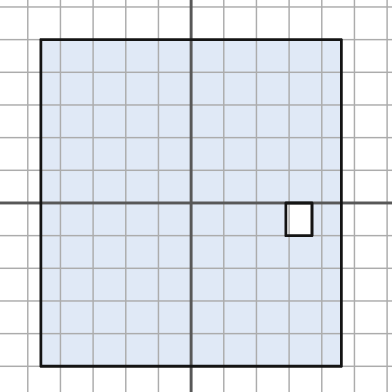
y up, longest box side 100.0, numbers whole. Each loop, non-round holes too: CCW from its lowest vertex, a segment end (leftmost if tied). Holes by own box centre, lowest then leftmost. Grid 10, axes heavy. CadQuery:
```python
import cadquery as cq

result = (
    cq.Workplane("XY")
    .moveTo(-46.0, -50.0)
    .lineTo(46.0, -50.0)
    .lineTo(46.0, 50.0)
    .lineTo(-46.0, 50.0)
    .close()
    .moveTo(29.0, -10.0)
    .lineTo(37.0, -10.0)
    .lineTo(37.0, 0.0)
    .lineTo(29.0, 0.0)
    .close()
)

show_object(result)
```